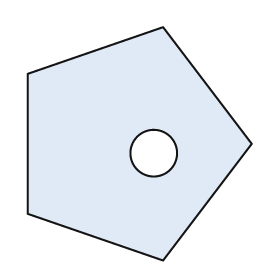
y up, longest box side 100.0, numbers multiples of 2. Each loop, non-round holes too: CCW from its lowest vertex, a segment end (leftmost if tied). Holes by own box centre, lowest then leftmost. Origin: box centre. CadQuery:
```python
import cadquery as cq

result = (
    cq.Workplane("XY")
    .moveTo(10.0, -50.0)
    .lineTo(48.0, 0.0)
    .lineTo(10.0, 50.0)
    .lineTo(-48.0, 30.0)
    .lineTo(-48.0, -30.0)
    .close()
    .moveTo(6.0, -4.0)
    .circle(10.0)
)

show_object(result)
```